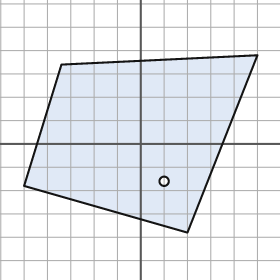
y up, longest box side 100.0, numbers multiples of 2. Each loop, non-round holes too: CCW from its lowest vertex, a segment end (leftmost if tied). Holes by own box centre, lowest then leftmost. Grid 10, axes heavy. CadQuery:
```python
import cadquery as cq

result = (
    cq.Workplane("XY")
    .moveTo(20.0, -38.0)
    .lineTo(50.0, 38.0)
    .lineTo(-34.0, 34.0)
    .lineTo(-50.0, -18.0)
    .close()
    .moveTo(10.0, -16.0)
    .circle(2.0)
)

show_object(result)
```